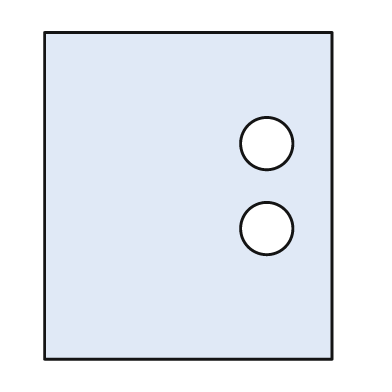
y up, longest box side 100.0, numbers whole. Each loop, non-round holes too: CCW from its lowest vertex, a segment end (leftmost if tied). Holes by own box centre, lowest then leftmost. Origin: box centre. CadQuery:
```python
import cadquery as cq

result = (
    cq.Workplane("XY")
    .moveTo(-44.0, -50.0)
    .lineTo(44.0, -50.0)
    .lineTo(44.0, 50.0)
    .lineTo(-44.0, 50.0)
    .close()
    .moveTo(24.0, -10.0)
    .circle(8.0)
    .moveTo(24.0, 16.0)
    .circle(8.0)
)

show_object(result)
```